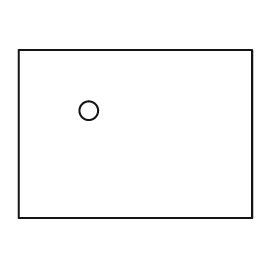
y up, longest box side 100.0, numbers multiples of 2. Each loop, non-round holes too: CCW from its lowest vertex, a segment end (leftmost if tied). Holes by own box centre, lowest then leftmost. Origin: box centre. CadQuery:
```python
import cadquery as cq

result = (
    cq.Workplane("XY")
    .moveTo(-50.0, -36.0)
    .lineTo(50.0, -36.0)
    .lineTo(50.0, 36.0)
    .lineTo(-50.0, 36.0)
    .close()
    .moveTo(-20.0, 10.0)
    .circle(4.0)
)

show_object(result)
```